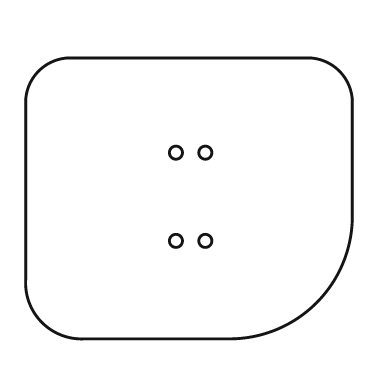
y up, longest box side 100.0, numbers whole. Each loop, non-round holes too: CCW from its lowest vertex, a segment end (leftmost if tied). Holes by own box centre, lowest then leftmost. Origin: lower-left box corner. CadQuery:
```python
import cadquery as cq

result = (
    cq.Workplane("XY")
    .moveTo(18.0, 0.0)
    .lineTo(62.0, 0.0)
    .threePointArc((89.0, 11.0), (100.0, 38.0))
    .lineTo(100.0, 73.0)
    .threePointArc((96.0, 82.0), (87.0, 86.0))
    .lineTo(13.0, 86.0)
    .threePointArc((4.0, 82.0), (0.0, 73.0))
    .lineTo(0.0, 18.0)
    .threePointArc((5.0, 5.0), (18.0, 0.0))
    .close()
    .moveTo(46.0, 30.0)
    .circle(2.0)
    .moveTo(55.0, 30.0)
    .circle(2.0)
    .moveTo(46.0, 57.0)
    .circle(2.0)
    .moveTo(55.0, 57.0)
    .circle(2.0)
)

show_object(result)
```